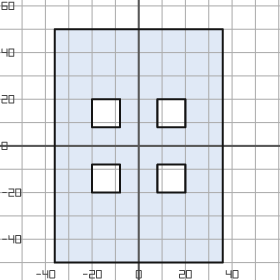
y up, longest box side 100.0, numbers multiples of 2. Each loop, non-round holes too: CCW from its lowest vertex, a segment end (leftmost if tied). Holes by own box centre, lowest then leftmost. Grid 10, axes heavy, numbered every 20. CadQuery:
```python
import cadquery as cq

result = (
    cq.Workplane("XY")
    .moveTo(-36.0, -50.0)
    .lineTo(36.0, -50.0)
    .lineTo(36.0, 50.0)
    .lineTo(-36.0, 50.0)
    .close()
    .moveTo(-20.0, -20.0)
    .lineTo(-8.0, -20.0)
    .lineTo(-8.0, -8.0)
    .lineTo(-20.0, -8.0)
    .close()
    .moveTo(8.0, -20.0)
    .lineTo(20.0, -20.0)
    .lineTo(20.0, -8.0)
    .lineTo(8.0, -8.0)
    .close()
    .moveTo(-20.0, 8.0)
    .lineTo(-8.0, 8.0)
    .lineTo(-8.0, 20.0)
    .lineTo(-20.0, 20.0)
    .close()
    .moveTo(8.0, 8.0)
    .lineTo(20.0, 8.0)
    .lineTo(20.0, 20.0)
    .lineTo(8.0, 20.0)
    .close()
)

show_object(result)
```